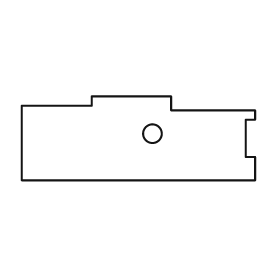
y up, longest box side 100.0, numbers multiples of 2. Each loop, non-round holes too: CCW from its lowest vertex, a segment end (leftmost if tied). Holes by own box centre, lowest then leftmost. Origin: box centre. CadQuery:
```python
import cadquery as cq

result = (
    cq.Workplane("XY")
    .moveTo(-50.0, -18.0)
    .lineTo(50.0, -18.0)
    .lineTo(50.0, -8.0)
    .lineTo(46.0, -8.0)
    .lineTo(46.0, 8.0)
    .lineTo(50.0, 8.0)
    .lineTo(50.0, 12.0)
    .lineTo(14.0, 12.0)
    .lineTo(14.0, 18.0)
    .lineTo(-20.0, 18.0)
    .lineTo(-20.0, 14.0)
    .lineTo(-50.0, 14.0)
    .close()
    .moveTo(6.0, 2.0)
    .circle(4.0)
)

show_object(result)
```